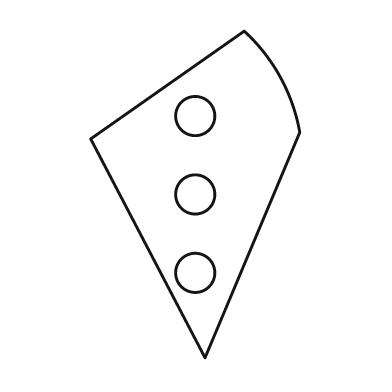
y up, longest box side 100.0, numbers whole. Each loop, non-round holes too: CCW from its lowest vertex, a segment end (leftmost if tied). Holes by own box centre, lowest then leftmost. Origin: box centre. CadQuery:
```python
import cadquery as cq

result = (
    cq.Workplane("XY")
    .moveTo(3.0, -50.0)
    .lineTo(32.0, 19.0)
    .threePointArc((26.0, 36.0), (15.0, 50.0))
    .lineTo(-32.0, 17.0)
    .close()
    .moveTo(0.0, -24.0)
    .circle(6.0)
    .moveTo(0.0, 0.0)
    .circle(6.0)
    .moveTo(0.0, 24.0)
    .circle(6.0)
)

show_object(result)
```